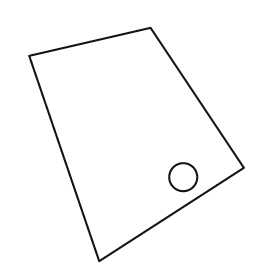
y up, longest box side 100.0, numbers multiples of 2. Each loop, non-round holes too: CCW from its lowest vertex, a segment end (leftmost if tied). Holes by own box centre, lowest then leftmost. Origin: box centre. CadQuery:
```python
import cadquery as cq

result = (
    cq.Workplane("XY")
    .moveTo(-16.0, -50.0)
    .lineTo(46.0, -10.0)
    .lineTo(6.0, 50.0)
    .lineTo(-46.0, 38.0)
    .close()
    .moveTo(20.0, -14.0)
    .circle(6.0)
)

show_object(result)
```